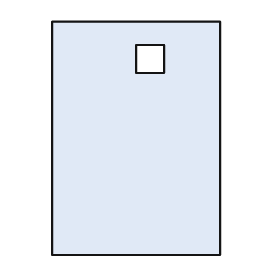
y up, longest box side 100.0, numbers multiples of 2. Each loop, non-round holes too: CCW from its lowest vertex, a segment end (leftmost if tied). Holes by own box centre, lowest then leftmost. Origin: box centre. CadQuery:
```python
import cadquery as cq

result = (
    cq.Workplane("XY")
    .moveTo(-36.0, -50.0)
    .lineTo(36.0, -50.0)
    .lineTo(36.0, 50.0)
    .lineTo(-36.0, 50.0)
    .close()
    .moveTo(0.0, 28.0)
    .lineTo(12.0, 28.0)
    .lineTo(12.0, 40.0)
    .lineTo(0.0, 40.0)
    .close()
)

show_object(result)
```